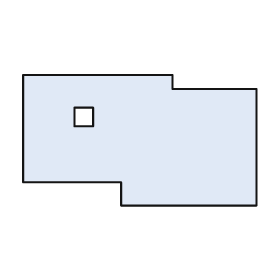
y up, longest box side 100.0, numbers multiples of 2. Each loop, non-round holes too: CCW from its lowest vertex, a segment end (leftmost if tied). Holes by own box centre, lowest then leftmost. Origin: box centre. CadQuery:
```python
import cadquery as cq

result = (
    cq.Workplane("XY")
    .moveTo(-8.0, -28.0)
    .lineTo(50.0, -28.0)
    .lineTo(50.0, 22.0)
    .lineTo(14.0, 22.0)
    .lineTo(14.0, 28.0)
    .lineTo(-50.0, 28.0)
    .lineTo(-50.0, -18.0)
    .lineTo(-8.0, -18.0)
    .close()
    .moveTo(-28.0, 6.0)
    .lineTo(-20.0, 6.0)
    .lineTo(-20.0, 14.0)
    .lineTo(-28.0, 14.0)
    .close()
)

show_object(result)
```